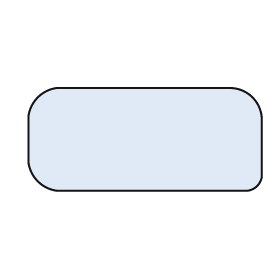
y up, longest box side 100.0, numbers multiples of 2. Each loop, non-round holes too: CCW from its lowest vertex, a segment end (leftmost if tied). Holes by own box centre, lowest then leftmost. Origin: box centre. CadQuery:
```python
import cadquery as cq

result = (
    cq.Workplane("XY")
    .moveTo(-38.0, -22.0)
    .lineTo(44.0, -22.0)
    .threePointArc((48.0, -20.0), (50.0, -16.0))
    .lineTo(50.0, 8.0)
    .threePointArc((46.0, 18.0), (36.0, 22.0))
    .lineTo(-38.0, 22.0)
    .threePointArc((-46.0, 18.0), (-50.0, 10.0))
    .lineTo(-50.0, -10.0)
    .threePointArc((-46.0, -18.0), (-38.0, -22.0))
    .close()
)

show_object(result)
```